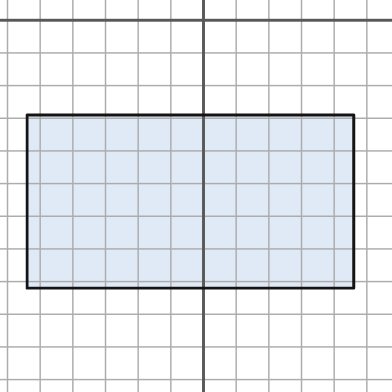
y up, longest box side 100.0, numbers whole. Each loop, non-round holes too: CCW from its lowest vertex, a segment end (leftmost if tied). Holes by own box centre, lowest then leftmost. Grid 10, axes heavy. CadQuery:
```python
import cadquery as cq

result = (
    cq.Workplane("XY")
    .moveTo(-54.0, -82.0)
    .lineTo(46.0, -82.0)
    .lineTo(46.0, -29.0)
    .lineTo(-54.0, -29.0)
    .close()
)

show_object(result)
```